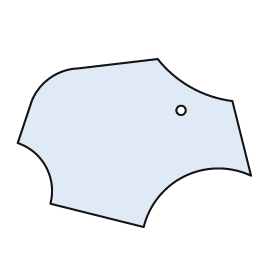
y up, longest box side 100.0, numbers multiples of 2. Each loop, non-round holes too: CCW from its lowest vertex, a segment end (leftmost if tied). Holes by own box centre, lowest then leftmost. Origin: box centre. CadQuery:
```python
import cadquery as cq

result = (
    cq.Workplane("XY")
    .moveTo(4.0, -36.0)
    .threePointArc((22.0, -14.0), (50.0, -14.0))
    .lineTo(42.0, 18.0)
    .threePointArc((24.0, 24.0), (10.0, 36.0))
    .lineTo(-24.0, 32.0)
    .threePointArc((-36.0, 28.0), (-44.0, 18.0))
    .lineTo(-50.0, 0.0)
    .threePointArc((-38.0, -10.0), (-36.0, -26.0))
    .close()
    .moveTo(20.0, 14.0)
    .circle(2.0)
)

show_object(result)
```